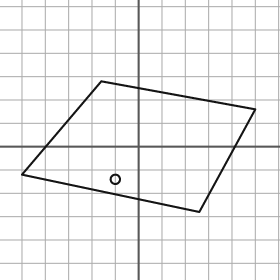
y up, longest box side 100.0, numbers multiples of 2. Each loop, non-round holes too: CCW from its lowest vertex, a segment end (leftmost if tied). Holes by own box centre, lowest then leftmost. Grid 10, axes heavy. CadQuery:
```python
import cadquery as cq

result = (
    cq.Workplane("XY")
    .moveTo(26.0, -28.0)
    .lineTo(50.0, 16.0)
    .lineTo(-16.0, 28.0)
    .lineTo(-50.0, -12.0)
    .close()
    .moveTo(-10.0, -14.0)
    .circle(2.0)
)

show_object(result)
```